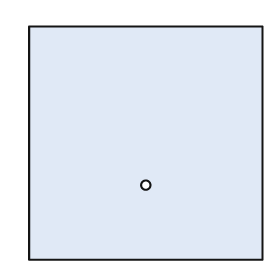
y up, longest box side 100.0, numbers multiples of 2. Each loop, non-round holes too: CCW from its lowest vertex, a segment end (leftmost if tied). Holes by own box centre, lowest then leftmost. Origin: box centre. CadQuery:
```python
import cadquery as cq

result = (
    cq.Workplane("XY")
    .moveTo(-50.0, -50.0)
    .lineTo(50.0, -50.0)
    .lineTo(50.0, 50.0)
    .lineTo(-50.0, 50.0)
    .close()
    .moveTo(0.0, -18.0)
    .circle(2.0)
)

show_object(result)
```